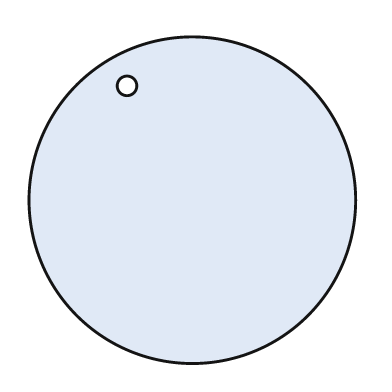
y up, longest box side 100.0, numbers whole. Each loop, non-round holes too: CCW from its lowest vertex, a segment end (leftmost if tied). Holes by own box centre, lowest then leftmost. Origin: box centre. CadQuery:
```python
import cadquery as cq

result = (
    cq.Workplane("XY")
    .moveTo(0.0, 0.0)
    .circle(50.0)
    .moveTo(-20.0, 35.0)
    .circle(3.0)
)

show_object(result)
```